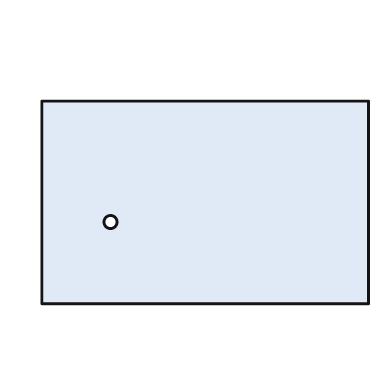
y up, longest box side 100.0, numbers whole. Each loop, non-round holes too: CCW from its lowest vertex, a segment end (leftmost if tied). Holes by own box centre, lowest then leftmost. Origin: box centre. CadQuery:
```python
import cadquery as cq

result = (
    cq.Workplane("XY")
    .moveTo(-50.0, -31.0)
    .lineTo(50.0, -31.0)
    .lineTo(50.0, 31.0)
    .lineTo(-50.0, 31.0)
    .close()
    .moveTo(-29.0, -6.0)
    .circle(2.0)
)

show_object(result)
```